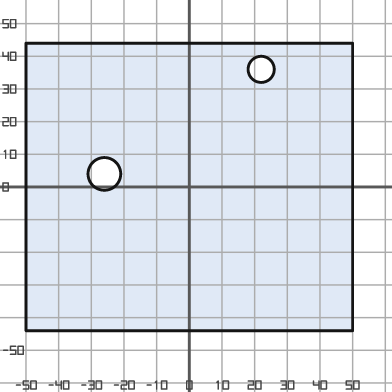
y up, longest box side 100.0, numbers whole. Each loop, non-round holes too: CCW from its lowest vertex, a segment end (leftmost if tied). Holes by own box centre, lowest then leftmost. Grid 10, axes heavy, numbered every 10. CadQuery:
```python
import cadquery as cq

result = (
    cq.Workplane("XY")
    .moveTo(-50.0, -44.0)
    .lineTo(50.0, -44.0)
    .lineTo(50.0, 44.0)
    .lineTo(-50.0, 44.0)
    .close()
    .moveTo(-26.0, 4.0)
    .circle(5.0)
    .moveTo(22.0, 36.0)
    .circle(4.0)
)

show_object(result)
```